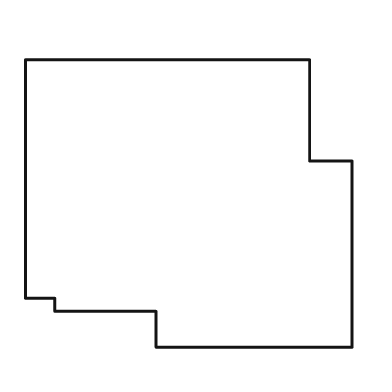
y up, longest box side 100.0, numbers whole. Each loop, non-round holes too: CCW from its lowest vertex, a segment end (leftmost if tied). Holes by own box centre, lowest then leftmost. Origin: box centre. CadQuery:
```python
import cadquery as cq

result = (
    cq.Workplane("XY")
    .moveTo(-10.0, -44.0)
    .lineTo(50.0, -44.0)
    .lineTo(50.0, 13.0)
    .lineTo(37.0, 13.0)
    .lineTo(37.0, 44.0)
    .lineTo(-50.0, 44.0)
    .lineTo(-50.0, -29.0)
    .lineTo(-41.0, -29.0)
    .lineTo(-41.0, -33.0)
    .lineTo(-10.0, -33.0)
    .close()
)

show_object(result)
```